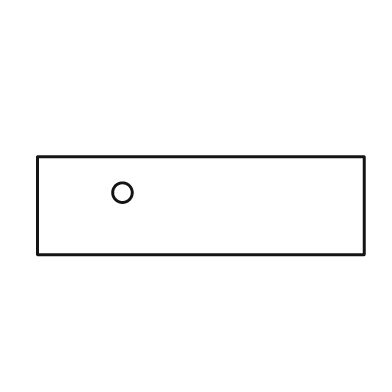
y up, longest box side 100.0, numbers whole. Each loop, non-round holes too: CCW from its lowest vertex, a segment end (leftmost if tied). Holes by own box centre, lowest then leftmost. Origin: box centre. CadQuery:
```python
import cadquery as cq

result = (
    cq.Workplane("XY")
    .moveTo(-50.0, -15.0)
    .lineTo(50.0, -15.0)
    .lineTo(50.0, 15.0)
    .lineTo(-50.0, 15.0)
    .close()
    .moveTo(-24.0, 4.0)
    .circle(3.0)
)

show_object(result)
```